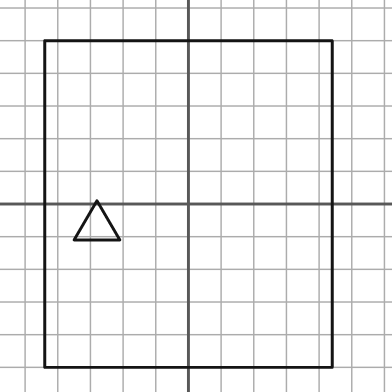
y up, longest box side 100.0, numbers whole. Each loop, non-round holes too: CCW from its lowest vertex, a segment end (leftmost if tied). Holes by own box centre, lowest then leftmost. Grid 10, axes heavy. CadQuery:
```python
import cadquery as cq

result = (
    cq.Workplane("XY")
    .moveTo(-44.0, -50.0)
    .lineTo(44.0, -50.0)
    .lineTo(44.0, 50.0)
    .lineTo(-44.0, 50.0)
    .close()
    .moveTo(-35.0, -11.0)
    .lineTo(-21.0, -11.0)
    .lineTo(-28.0, 1.0)
    .close()
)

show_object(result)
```